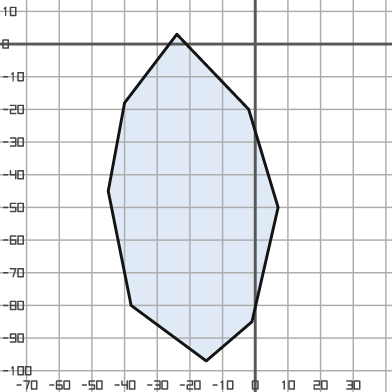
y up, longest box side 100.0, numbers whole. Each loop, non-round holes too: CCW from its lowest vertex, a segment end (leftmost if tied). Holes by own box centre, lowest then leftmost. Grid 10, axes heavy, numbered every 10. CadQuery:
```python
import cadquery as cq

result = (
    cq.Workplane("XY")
    .moveTo(-15.0, -97.0)
    .lineTo(-1.0, -85.0)
    .lineTo(7.0, -50.0)
    .lineTo(-2.0, -20.0)
    .lineTo(-24.0, 3.0)
    .lineTo(-40.0, -18.0)
    .lineTo(-45.0, -45.0)
    .lineTo(-38.0, -80.0)
    .close()
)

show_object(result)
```